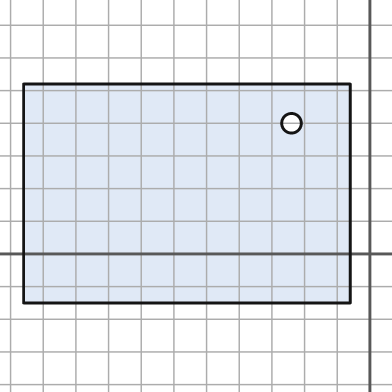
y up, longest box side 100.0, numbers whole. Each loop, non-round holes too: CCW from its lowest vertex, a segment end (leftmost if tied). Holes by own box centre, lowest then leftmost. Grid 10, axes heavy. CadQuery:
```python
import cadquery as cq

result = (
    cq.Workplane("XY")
    .moveTo(-106.0, -15.0)
    .lineTo(-6.0, -15.0)
    .lineTo(-6.0, 52.0)
    .lineTo(-106.0, 52.0)
    .close()
    .moveTo(-24.0, 40.0)
    .circle(3.0)
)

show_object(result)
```